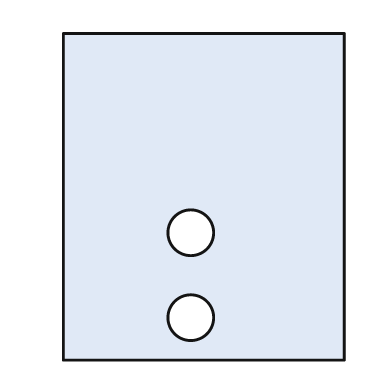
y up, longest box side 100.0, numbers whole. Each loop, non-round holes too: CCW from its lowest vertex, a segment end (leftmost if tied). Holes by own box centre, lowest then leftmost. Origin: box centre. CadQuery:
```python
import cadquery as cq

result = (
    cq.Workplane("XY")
    .moveTo(-43.0, -50.0)
    .lineTo(43.0, -50.0)
    .lineTo(43.0, 50.0)
    .lineTo(-43.0, 50.0)
    .close()
    .moveTo(-4.0, -37.0)
    .circle(7.0)
    .moveTo(-4.0, -11.0)
    .circle(7.0)
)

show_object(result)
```